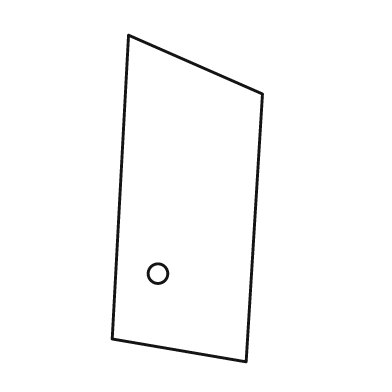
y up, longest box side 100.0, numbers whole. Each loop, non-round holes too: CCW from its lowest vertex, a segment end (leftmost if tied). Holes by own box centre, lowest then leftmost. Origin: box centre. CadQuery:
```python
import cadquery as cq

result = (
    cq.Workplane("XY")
    .moveTo(18.0, -50.0)
    .lineTo(23.0, 32.0)
    .lineTo(-18.0, 50.0)
    .lineTo(-23.0, -43.0)
    .close()
    .moveTo(-9.0, -23.0)
    .circle(3.0)
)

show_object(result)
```